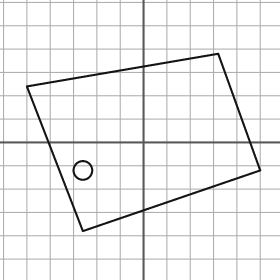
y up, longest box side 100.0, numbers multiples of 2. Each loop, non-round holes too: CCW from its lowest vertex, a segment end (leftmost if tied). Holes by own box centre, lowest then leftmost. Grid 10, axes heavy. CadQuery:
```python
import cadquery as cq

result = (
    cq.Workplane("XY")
    .moveTo(-26.0, -38.0)
    .lineTo(50.0, -12.0)
    .lineTo(32.0, 38.0)
    .lineTo(-50.0, 24.0)
    .close()
    .moveTo(-26.0, -12.0)
    .circle(4.0)
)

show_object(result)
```